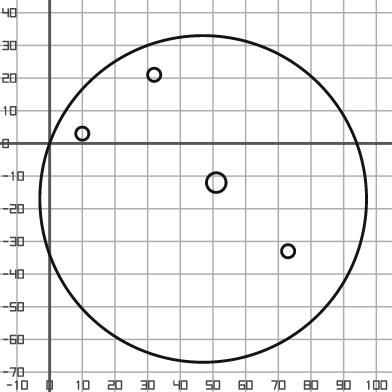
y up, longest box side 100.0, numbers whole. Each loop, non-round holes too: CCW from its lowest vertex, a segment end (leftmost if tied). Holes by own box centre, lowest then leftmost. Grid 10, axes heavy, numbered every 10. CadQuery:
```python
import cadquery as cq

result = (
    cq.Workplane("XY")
    .moveTo(47.0, -17.0)
    .circle(50.0)
    .moveTo(73.0, -33.0)
    .circle(2.0)
    .moveTo(51.0, -12.0)
    .circle(3.0)
    .moveTo(10.0, 3.0)
    .circle(2.0)
    .moveTo(32.0, 21.0)
    .circle(2.0)
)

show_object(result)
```